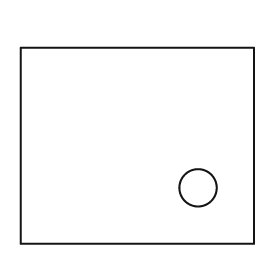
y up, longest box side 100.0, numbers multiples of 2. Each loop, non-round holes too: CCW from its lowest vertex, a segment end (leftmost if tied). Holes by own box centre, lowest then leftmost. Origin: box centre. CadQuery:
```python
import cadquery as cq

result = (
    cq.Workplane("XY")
    .moveTo(-50.0, -42.0)
    .lineTo(50.0, -42.0)
    .lineTo(50.0, 42.0)
    .lineTo(-50.0, 42.0)
    .close()
    .moveTo(26.0, -18.0)
    .circle(8.0)
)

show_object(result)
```